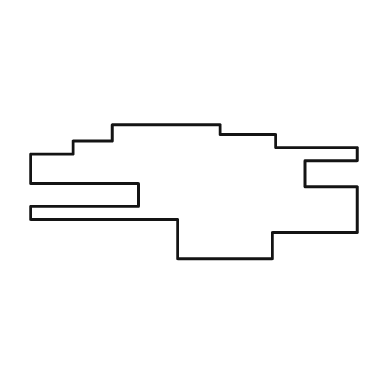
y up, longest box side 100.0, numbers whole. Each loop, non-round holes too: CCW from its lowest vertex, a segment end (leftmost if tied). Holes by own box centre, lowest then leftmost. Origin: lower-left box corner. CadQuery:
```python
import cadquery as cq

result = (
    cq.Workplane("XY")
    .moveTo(45.0, 0.0)
    .lineTo(74.0, 0.0)
    .lineTo(74.0, 8.0)
    .lineTo(100.0, 8.0)
    .lineTo(100.0, 22.0)
    .lineTo(84.0, 22.0)
    .lineTo(84.0, 30.0)
    .lineTo(100.0, 30.0)
    .lineTo(100.0, 34.0)
    .lineTo(75.0, 34.0)
    .lineTo(75.0, 38.0)
    .lineTo(58.0, 38.0)
    .lineTo(58.0, 41.0)
    .lineTo(25.0, 41.0)
    .lineTo(25.0, 36.0)
    .lineTo(13.0, 36.0)
    .lineTo(13.0, 32.0)
    .lineTo(0.0, 32.0)
    .lineTo(0.0, 23.0)
    .lineTo(33.0, 23.0)
    .lineTo(33.0, 16.0)
    .lineTo(0.0, 16.0)
    .lineTo(0.0, 12.0)
    .lineTo(45.0, 12.0)
    .close()
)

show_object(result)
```